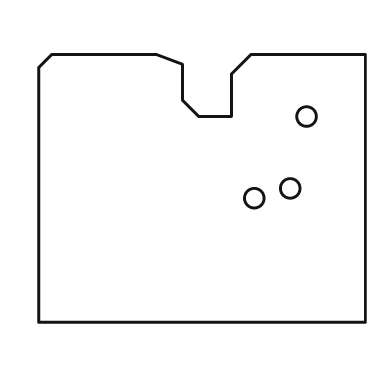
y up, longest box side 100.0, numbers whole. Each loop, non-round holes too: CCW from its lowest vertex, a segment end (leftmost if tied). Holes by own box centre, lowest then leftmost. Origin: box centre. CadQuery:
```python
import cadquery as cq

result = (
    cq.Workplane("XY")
    .moveTo(-50.0, -41.0)
    .lineTo(50.0, -41.0)
    .lineTo(50.0, 41.0)
    .lineTo(15.0, 41.0)
    .lineTo(9.0, 35.0)
    .lineTo(9.0, 22.0)
    .lineTo(-1.0, 22.0)
    .lineTo(-6.0, 27.0)
    .lineTo(-6.0, 38.0)
    .lineTo(-14.0, 41.0)
    .lineTo(-46.0, 41.0)
    .lineTo(-50.0, 37.0)
    .close()
    .moveTo(16.0, -3.0)
    .circle(3.0)
    .moveTo(27.0, 0.0)
    .circle(3.0)
    .moveTo(32.0, 22.0)
    .circle(3.0)
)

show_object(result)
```